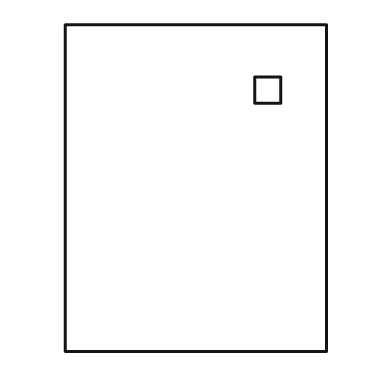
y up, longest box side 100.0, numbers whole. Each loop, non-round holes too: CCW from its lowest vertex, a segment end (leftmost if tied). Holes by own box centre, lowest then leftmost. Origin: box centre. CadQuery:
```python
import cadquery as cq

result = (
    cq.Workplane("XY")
    .moveTo(-40.0, -50.0)
    .lineTo(40.0, -50.0)
    .lineTo(40.0, 50.0)
    .lineTo(-40.0, 50.0)
    .close()
    .moveTo(18.0, 26.0)
    .lineTo(26.0, 26.0)
    .lineTo(26.0, 34.0)
    .lineTo(18.0, 34.0)
    .close()
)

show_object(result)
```